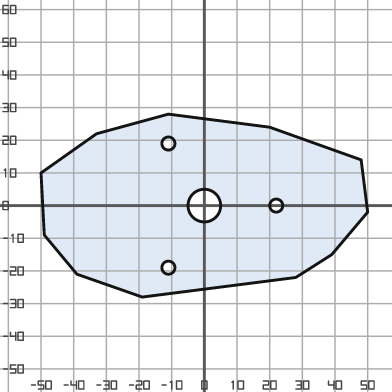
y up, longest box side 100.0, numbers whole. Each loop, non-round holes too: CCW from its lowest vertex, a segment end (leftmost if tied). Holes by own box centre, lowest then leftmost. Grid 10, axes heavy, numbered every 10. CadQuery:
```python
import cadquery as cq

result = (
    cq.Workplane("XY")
    .moveTo(-19.0, -28.0)
    .lineTo(28.0, -22.0)
    .lineTo(39.0, -15.0)
    .lineTo(50.0, -2.0)
    .lineTo(48.0, 14.0)
    .lineTo(20.0, 24.0)
    .lineTo(-11.0, 28.0)
    .lineTo(-33.0, 22.0)
    .lineTo(-50.0, 10.0)
    .lineTo(-49.0, -9.0)
    .lineTo(-39.0, -21.0)
    .close()
    .moveTo(-11.0, -19.0)
    .circle(2.0)
    .moveTo(0.0, 0.0)
    .circle(5.0)
    .moveTo(22.0, 0.0)
    .circle(2.0)
    .moveTo(-11.0, 19.0)
    .circle(2.0)
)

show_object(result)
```